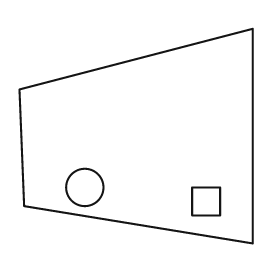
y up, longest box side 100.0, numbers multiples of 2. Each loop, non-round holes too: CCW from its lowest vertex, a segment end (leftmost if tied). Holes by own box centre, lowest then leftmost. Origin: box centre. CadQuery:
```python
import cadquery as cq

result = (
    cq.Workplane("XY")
    .moveTo(50.0, -46.0)
    .lineTo(50.0, 46.0)
    .lineTo(-50.0, 20.0)
    .lineTo(-48.0, -30.0)
    .close()
    .moveTo(24.0, -34.0)
    .lineTo(36.0, -34.0)
    .lineTo(36.0, -22.0)
    .lineTo(24.0, -22.0)
    .close()
    .moveTo(-22.0, -22.0)
    .circle(8.0)
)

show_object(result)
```